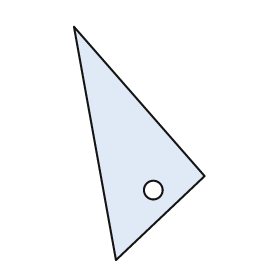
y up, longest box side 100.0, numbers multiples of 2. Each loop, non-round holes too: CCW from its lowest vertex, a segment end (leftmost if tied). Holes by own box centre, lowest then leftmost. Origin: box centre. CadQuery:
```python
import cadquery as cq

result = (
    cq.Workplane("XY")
    .moveTo(-10.0, -50.0)
    .lineTo(28.0, -14.0)
    .lineTo(-28.0, 50.0)
    .close()
    .moveTo(6.0, -20.0)
    .circle(4.0)
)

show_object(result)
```